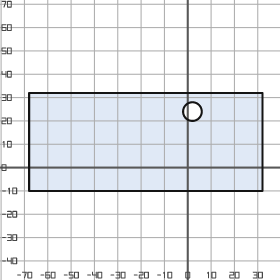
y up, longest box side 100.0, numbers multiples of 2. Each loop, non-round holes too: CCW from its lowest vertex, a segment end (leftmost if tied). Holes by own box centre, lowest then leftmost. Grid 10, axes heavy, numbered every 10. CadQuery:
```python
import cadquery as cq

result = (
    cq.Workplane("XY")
    .moveTo(-68.0, -10.0)
    .lineTo(32.0, -10.0)
    .lineTo(32.0, 32.0)
    .lineTo(-68.0, 32.0)
    .close()
    .moveTo(2.0, 24.0)
    .circle(4.0)
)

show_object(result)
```